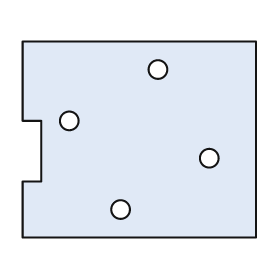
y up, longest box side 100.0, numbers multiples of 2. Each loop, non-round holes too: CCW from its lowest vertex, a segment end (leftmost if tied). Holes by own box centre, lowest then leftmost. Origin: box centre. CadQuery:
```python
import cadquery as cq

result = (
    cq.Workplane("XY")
    .moveTo(-50.0, -42.0)
    .lineTo(50.0, -42.0)
    .lineTo(50.0, 42.0)
    .lineTo(-50.0, 42.0)
    .lineTo(-50.0, 8.0)
    .lineTo(-42.0, 8.0)
    .lineTo(-42.0, -18.0)
    .lineTo(-50.0, -18.0)
    .close()
    .moveTo(-8.0, -30.0)
    .circle(4.0)
    .moveTo(30.0, -8.0)
    .circle(4.0)
    .moveTo(-30.0, 8.0)
    .circle(4.0)
    .moveTo(8.0, 30.0)
    .circle(4.0)
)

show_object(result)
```